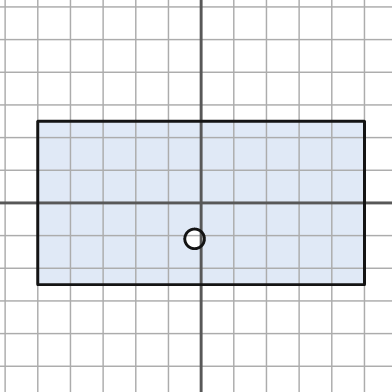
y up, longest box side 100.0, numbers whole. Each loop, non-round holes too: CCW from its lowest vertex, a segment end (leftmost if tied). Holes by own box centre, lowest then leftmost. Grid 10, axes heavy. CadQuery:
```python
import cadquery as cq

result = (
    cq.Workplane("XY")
    .moveTo(-50.0, -25.0)
    .lineTo(50.0, -25.0)
    .lineTo(50.0, 25.0)
    .lineTo(-50.0, 25.0)
    .close()
    .moveTo(-2.0, -11.0)
    .circle(3.0)
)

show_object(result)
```